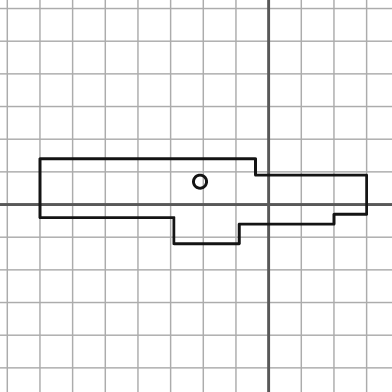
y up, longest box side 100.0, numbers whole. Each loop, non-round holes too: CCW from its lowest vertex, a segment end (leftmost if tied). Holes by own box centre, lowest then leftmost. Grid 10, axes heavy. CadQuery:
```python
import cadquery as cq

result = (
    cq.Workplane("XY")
    .moveTo(-29.0, -12.0)
    .lineTo(-9.0, -12.0)
    .lineTo(-9.0, -6.0)
    .lineTo(20.0, -6.0)
    .lineTo(20.0, -3.0)
    .lineTo(30.0, -3.0)
    .lineTo(30.0, 9.0)
    .lineTo(-4.0, 9.0)
    .lineTo(-4.0, 14.0)
    .lineTo(-70.0, 14.0)
    .lineTo(-70.0, -4.0)
    .lineTo(-29.0, -4.0)
    .close()
    .moveTo(-21.0, 7.0)
    .circle(2.0)
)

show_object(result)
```